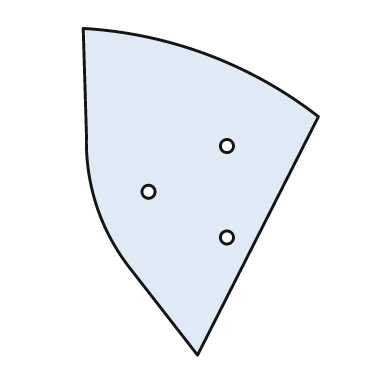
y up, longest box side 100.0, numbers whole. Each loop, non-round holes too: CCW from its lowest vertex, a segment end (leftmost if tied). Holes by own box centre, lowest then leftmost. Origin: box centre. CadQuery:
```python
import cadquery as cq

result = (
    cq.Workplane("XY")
    .moveTo(-1.0, -50.0)
    .lineTo(36.0, 23.0)
    .threePointArc((2.0, 42.0), (-36.0, 50.0))
    .lineTo(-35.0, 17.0)
    .threePointArc((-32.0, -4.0), (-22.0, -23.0))
    .close()
    .moveTo(8.0, -14.0)
    .circle(2.0)
    .moveTo(-16.0, 0.0)
    .circle(2.0)
    .moveTo(8.0, 14.0)
    .circle(2.0)
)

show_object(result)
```